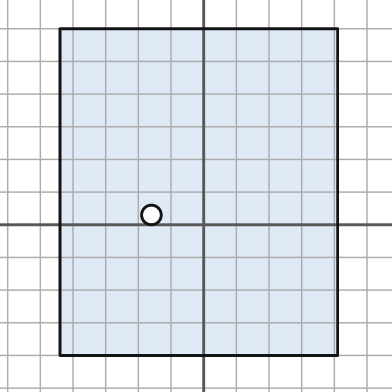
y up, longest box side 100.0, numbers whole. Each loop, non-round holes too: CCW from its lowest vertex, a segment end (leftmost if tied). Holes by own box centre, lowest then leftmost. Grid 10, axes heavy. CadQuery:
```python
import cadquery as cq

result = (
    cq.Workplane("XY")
    .moveTo(-44.0, -40.0)
    .lineTo(41.0, -40.0)
    .lineTo(41.0, 60.0)
    .lineTo(-44.0, 60.0)
    .close()
    .moveTo(-16.0, 3.0)
    .circle(3.0)
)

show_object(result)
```